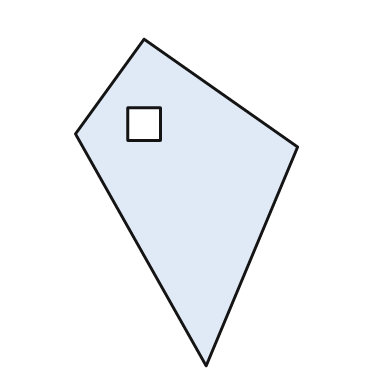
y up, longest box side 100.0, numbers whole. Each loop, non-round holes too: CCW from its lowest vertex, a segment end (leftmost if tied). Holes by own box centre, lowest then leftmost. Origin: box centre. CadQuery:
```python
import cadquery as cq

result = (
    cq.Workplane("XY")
    .moveTo(6.0, -50.0)
    .lineTo(34.0, 17.0)
    .lineTo(-13.0, 50.0)
    .lineTo(-34.0, 21.0)
    .close()
    .moveTo(-18.0, 19.0)
    .lineTo(-8.0, 19.0)
    .lineTo(-8.0, 29.0)
    .lineTo(-18.0, 29.0)
    .close()
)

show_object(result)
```